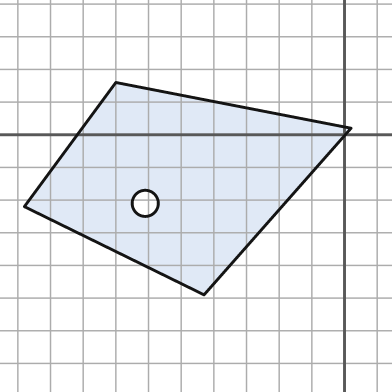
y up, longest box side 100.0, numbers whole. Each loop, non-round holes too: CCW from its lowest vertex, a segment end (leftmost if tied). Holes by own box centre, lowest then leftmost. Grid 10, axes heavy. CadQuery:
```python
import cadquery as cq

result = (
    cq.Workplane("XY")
    .moveTo(-43.0, -49.0)
    .lineTo(2.0, 2.0)
    .lineTo(-70.0, 16.0)
    .lineTo(-98.0, -22.0)
    .close()
    .moveTo(-61.0, -21.0)
    .circle(4.0)
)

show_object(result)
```